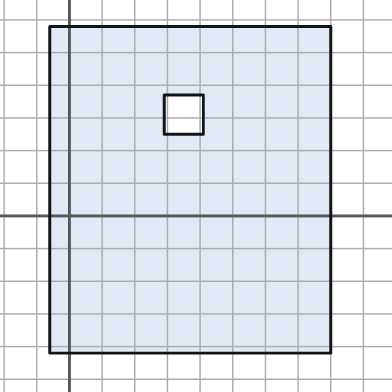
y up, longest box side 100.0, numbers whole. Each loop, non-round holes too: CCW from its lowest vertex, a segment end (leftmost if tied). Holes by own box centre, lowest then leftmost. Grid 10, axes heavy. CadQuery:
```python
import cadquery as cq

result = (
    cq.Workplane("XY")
    .moveTo(-6.0, -42.0)
    .lineTo(80.0, -42.0)
    .lineTo(80.0, 58.0)
    .lineTo(-6.0, 58.0)
    .close()
    .moveTo(29.0, 25.0)
    .lineTo(41.0, 25.0)
    .lineTo(41.0, 37.0)
    .lineTo(29.0, 37.0)
    .close()
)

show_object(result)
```